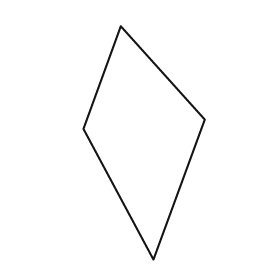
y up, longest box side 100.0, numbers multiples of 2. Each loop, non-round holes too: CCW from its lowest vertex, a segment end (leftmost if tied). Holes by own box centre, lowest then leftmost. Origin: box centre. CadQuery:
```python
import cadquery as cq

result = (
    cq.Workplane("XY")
    .moveTo(4.0, -50.0)
    .lineTo(26.0, 10.0)
    .lineTo(-10.0, 50.0)
    .lineTo(-26.0, 6.0)
    .close()
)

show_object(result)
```